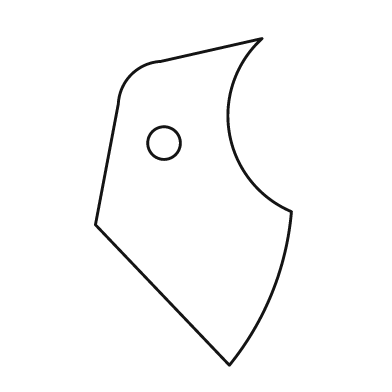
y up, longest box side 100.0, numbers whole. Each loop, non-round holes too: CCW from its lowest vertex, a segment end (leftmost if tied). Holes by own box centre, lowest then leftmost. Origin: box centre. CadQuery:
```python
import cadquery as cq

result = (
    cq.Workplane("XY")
    .moveTo(11.0, -50.0)
    .threePointArc((24.0, -28.0), (30.0, -3.0))
    .threePointArc((11.0, 21.0), (21.0, 50.0))
    .lineTo(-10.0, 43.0)
    .threePointArc((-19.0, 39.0), (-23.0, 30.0))
    .lineTo(-30.0, -7.0)
    .close()
    .moveTo(-9.0, 18.0)
    .circle(5.0)
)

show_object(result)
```